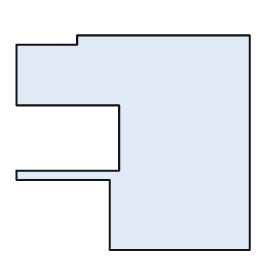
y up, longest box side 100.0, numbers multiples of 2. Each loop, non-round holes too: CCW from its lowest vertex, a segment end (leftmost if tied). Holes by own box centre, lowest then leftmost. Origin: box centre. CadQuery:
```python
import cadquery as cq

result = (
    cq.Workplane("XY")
    .moveTo(-10.0, -46.0)
    .lineTo(50.0, -46.0)
    .lineTo(50.0, 46.0)
    .lineTo(-24.0, 46.0)
    .lineTo(-24.0, 42.0)
    .lineTo(-50.0, 42.0)
    .lineTo(-50.0, 16.0)
    .lineTo(-6.0, 16.0)
    .lineTo(-6.0, -12.0)
    .lineTo(-50.0, -12.0)
    .lineTo(-50.0, -16.0)
    .lineTo(-10.0, -16.0)
    .close()
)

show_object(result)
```